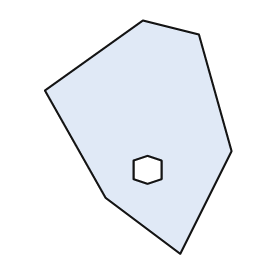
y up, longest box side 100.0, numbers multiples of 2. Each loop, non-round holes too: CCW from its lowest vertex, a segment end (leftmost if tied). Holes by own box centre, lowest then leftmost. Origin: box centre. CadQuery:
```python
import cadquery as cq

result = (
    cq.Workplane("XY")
    .moveTo(18.0, -50.0)
    .lineTo(40.0, -6.0)
    .lineTo(26.0, 44.0)
    .lineTo(2.0, 50.0)
    .lineTo(-40.0, 20.0)
    .lineTo(-14.0, -26.0)
    .close()
    .moveTo(4.0, -20.0)
    .lineTo(10.0, -18.0)
    .lineTo(10.0, -10.0)
    .lineTo(4.0, -8.0)
    .lineTo(-2.0, -10.0)
    .lineTo(-2.0, -18.0)
    .close()
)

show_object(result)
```